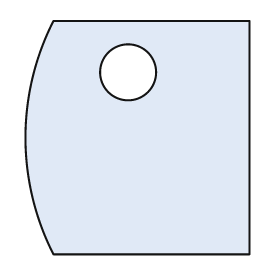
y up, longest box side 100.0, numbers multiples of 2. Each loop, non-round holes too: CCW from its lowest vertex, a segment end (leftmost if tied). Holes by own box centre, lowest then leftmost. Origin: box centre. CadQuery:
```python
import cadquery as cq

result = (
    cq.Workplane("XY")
    .moveTo(-36.0, -50.0)
    .lineTo(48.0, -50.0)
    .lineTo(48.0, 50.0)
    .lineTo(-36.0, 50.0)
    .threePointArc((-48.0, 0.0), (-36.0, -50.0))
    .close()
    .moveTo(-4.0, 28.0)
    .circle(12.0)
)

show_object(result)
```